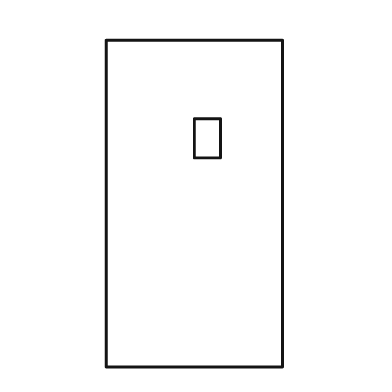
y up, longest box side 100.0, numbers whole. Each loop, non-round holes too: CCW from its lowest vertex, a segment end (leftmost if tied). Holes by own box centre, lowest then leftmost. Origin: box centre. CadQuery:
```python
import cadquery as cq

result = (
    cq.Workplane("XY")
    .moveTo(-27.0, -50.0)
    .lineTo(27.0, -50.0)
    .lineTo(27.0, 50.0)
    .lineTo(-27.0, 50.0)
    .close()
    .moveTo(0.0, 14.0)
    .lineTo(8.0, 14.0)
    .lineTo(8.0, 26.0)
    .lineTo(0.0, 26.0)
    .close()
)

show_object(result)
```